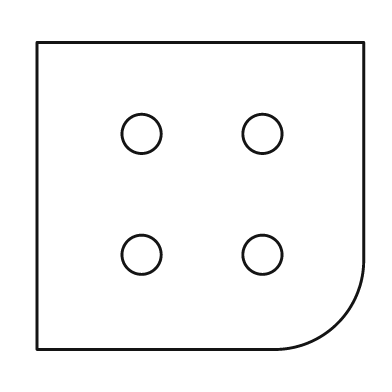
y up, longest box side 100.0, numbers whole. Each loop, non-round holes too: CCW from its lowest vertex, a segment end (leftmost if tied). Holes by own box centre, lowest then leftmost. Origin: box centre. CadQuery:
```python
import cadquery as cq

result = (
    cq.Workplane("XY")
    .moveTo(-50.0, -47.0)
    .lineTo(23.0, -47.0)
    .threePointArc((42.0, -39.0), (50.0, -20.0))
    .lineTo(50.0, 47.0)
    .lineTo(-50.0, 47.0)
    .close()
    .moveTo(-18.0, -18.0)
    .circle(6.0)
    .moveTo(19.0, -18.0)
    .circle(6.0)
    .moveTo(-18.0, 19.0)
    .circle(6.0)
    .moveTo(19.0, 19.0)
    .circle(6.0)
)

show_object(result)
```